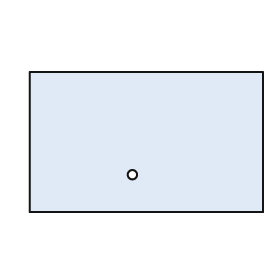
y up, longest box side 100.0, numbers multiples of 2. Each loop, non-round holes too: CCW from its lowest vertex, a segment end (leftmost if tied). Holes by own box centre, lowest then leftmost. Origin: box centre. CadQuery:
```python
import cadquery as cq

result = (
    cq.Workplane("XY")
    .moveTo(-50.0, -30.0)
    .lineTo(50.0, -30.0)
    .lineTo(50.0, 30.0)
    .lineTo(-50.0, 30.0)
    .close()
    .moveTo(-6.0, -14.0)
    .circle(2.0)
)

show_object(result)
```